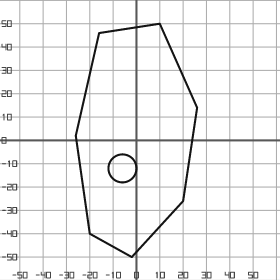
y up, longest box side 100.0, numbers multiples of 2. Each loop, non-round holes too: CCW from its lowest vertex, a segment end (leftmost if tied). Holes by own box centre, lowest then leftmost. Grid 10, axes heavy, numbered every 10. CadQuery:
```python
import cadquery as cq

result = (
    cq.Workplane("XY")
    .moveTo(-2.0, -50.0)
    .lineTo(20.0, -26.0)
    .lineTo(26.0, 14.0)
    .lineTo(10.0, 50.0)
    .lineTo(-16.0, 46.0)
    .lineTo(-26.0, 2.0)
    .lineTo(-20.0, -40.0)
    .close()
    .moveTo(-6.0, -12.0)
    .circle(6.0)
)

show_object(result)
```